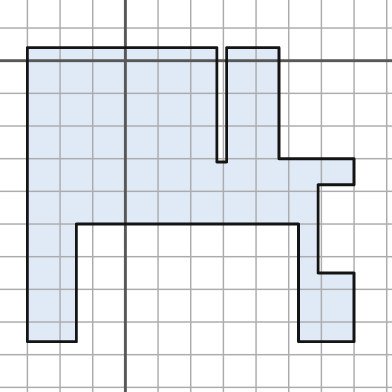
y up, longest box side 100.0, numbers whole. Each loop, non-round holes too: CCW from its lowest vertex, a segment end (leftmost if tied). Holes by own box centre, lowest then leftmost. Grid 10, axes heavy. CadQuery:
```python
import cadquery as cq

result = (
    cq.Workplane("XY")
    .moveTo(-30.0, -86.0)
    .lineTo(-15.0, -86.0)
    .lineTo(-15.0, -50.0)
    .lineTo(53.0, -50.0)
    .lineTo(53.0, -86.0)
    .lineTo(70.0, -86.0)
    .lineTo(70.0, -65.0)
    .lineTo(59.0, -65.0)
    .lineTo(59.0, -38.0)
    .lineTo(70.0, -38.0)
    .lineTo(70.0, -30.0)
    .lineTo(47.0, -30.0)
    .lineTo(47.0, 4.0)
    .lineTo(31.0, 4.0)
    .lineTo(31.0, -31.0)
    .lineTo(28.0, -31.0)
    .lineTo(28.0, 4.0)
    .lineTo(-30.0, 4.0)
    .close()
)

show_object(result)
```